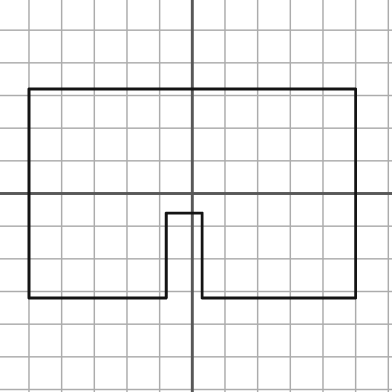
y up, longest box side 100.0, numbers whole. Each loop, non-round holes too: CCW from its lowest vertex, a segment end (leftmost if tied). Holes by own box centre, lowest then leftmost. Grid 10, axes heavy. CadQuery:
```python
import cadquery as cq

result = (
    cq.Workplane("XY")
    .moveTo(-50.0, -32.0)
    .lineTo(-8.0, -32.0)
    .lineTo(-8.0, -6.0)
    .lineTo(3.0, -6.0)
    .lineTo(3.0, -32.0)
    .lineTo(50.0, -32.0)
    .lineTo(50.0, 32.0)
    .lineTo(-50.0, 32.0)
    .close()
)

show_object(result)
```